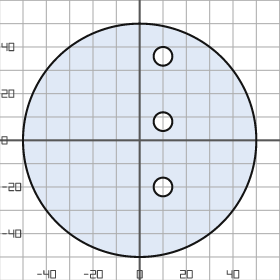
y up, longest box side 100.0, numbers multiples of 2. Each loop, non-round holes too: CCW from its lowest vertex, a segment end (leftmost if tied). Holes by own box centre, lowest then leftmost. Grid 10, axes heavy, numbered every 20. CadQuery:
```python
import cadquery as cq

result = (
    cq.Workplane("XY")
    .moveTo(0.0, 0.0)
    .circle(50.0)
    .moveTo(10.0, -20.0)
    .circle(4.0)
    .moveTo(10.0, 8.0)
    .circle(4.0)
    .moveTo(10.0, 36.0)
    .circle(4.0)
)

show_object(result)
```